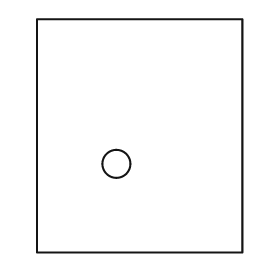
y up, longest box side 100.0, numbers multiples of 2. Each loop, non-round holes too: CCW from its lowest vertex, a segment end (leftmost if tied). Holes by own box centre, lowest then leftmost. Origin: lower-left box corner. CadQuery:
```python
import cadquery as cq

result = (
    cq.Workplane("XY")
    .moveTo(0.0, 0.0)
    .lineTo(88.0, 0.0)
    .lineTo(88.0, 100.0)
    .lineTo(0.0, 100.0)
    .close()
    .moveTo(34.0, 38.0)
    .circle(6.0)
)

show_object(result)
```